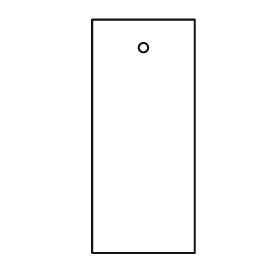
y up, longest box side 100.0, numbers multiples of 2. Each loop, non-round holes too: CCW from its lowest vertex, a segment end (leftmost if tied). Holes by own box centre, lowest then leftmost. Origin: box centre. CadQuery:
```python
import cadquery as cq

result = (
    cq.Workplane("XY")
    .moveTo(-22.0, -50.0)
    .lineTo(22.0, -50.0)
    .lineTo(22.0, 50.0)
    .lineTo(-22.0, 50.0)
    .close()
    .moveTo(0.0, 38.0)
    .circle(2.0)
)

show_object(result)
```